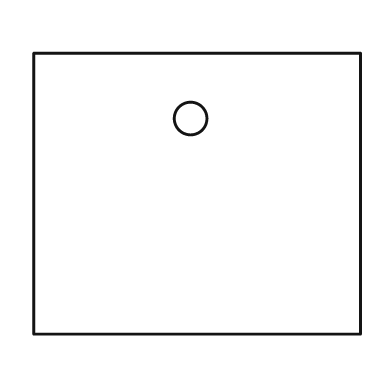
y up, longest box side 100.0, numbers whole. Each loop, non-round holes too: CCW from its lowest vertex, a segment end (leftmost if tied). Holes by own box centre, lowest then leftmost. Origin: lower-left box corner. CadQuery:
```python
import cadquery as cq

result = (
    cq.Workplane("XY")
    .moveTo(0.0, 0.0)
    .lineTo(100.0, 0.0)
    .lineTo(100.0, 86.0)
    .lineTo(0.0, 86.0)
    .close()
    .moveTo(48.0, 66.0)
    .circle(5.0)
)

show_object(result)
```